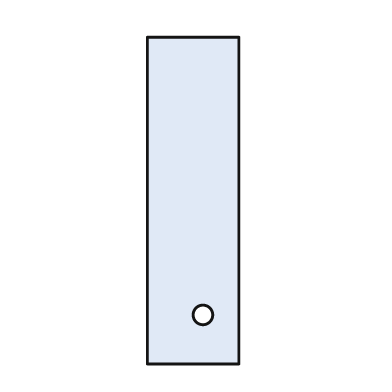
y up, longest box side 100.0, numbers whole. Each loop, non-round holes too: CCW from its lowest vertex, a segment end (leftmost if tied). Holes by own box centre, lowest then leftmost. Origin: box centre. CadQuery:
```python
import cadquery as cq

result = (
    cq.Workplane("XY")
    .moveTo(-14.0, -50.0)
    .lineTo(14.0, -50.0)
    .lineTo(14.0, 50.0)
    .lineTo(-14.0, 50.0)
    .close()
    .moveTo(3.0, -35.0)
    .circle(3.0)
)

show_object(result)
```